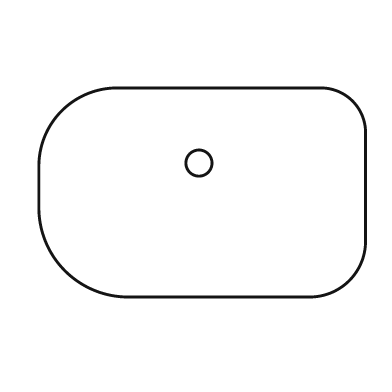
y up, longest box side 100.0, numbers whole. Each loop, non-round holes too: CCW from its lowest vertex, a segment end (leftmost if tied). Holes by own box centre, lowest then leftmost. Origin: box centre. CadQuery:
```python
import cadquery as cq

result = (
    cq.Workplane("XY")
    .moveTo(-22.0, -32.0)
    .lineTo(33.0, -32.0)
    .threePointArc((45.0, -27.0), (50.0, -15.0))
    .lineTo(50.0, 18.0)
    .threePointArc((46.0, 28.0), (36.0, 32.0))
    .lineTo(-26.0, 32.0)
    .threePointArc((-43.0, 25.0), (-50.0, 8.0))
    .lineTo(-50.0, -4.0)
    .threePointArc((-42.0, -24.0), (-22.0, -32.0))
    .close()
    .moveTo(-1.0, 9.0)
    .circle(4.0)
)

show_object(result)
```